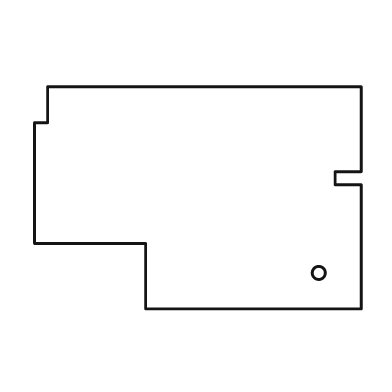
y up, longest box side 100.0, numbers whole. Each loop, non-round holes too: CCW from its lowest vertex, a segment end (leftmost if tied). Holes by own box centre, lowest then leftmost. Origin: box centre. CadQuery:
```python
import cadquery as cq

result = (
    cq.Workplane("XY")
    .moveTo(-16.0, -34.0)
    .lineTo(50.0, -34.0)
    .lineTo(50.0, 4.0)
    .lineTo(42.0, 4.0)
    .lineTo(42.0, 8.0)
    .lineTo(50.0, 8.0)
    .lineTo(50.0, 34.0)
    .lineTo(-46.0, 34.0)
    .lineTo(-46.0, 23.0)
    .lineTo(-50.0, 23.0)
    .lineTo(-50.0, -14.0)
    .lineTo(-16.0, -14.0)
    .close()
    .moveTo(37.0, -23.0)
    .circle(2.0)
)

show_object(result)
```